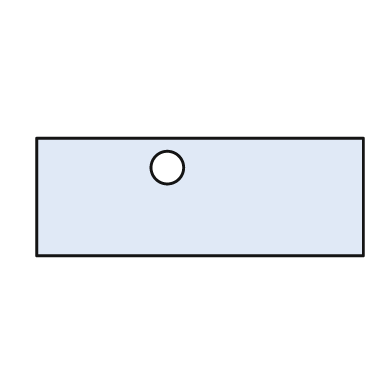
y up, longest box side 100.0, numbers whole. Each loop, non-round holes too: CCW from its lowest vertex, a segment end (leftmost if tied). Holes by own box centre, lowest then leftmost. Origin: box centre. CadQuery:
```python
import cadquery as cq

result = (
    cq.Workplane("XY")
    .moveTo(-50.0, -18.0)
    .lineTo(50.0, -18.0)
    .lineTo(50.0, 18.0)
    .lineTo(-50.0, 18.0)
    .close()
    .moveTo(-10.0, 9.0)
    .circle(5.0)
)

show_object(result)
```